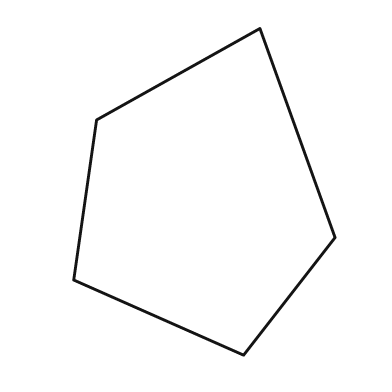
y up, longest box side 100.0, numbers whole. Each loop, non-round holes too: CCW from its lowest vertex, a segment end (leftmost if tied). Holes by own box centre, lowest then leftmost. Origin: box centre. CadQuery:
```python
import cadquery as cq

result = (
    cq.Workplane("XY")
    .moveTo(12.0, -50.0)
    .lineTo(40.0, -14.0)
    .lineTo(17.0, 50.0)
    .lineTo(-33.0, 22.0)
    .lineTo(-40.0, -27.0)
    .close()
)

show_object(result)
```